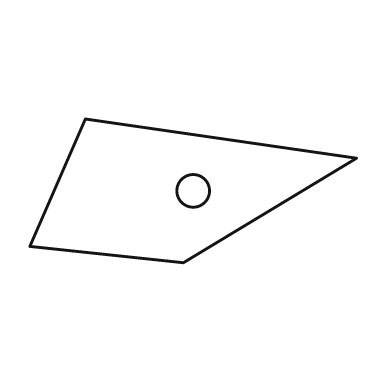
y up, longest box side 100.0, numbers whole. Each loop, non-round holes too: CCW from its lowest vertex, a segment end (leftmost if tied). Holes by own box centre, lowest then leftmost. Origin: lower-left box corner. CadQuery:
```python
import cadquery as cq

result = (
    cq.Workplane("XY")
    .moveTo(47.0, 0.0)
    .lineTo(100.0, 32.0)
    .lineTo(17.0, 44.0)
    .lineTo(0.0, 5.0)
    .close()
    .moveTo(50.0, 22.0)
    .circle(5.0)
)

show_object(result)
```